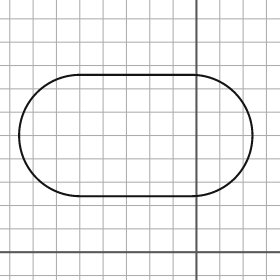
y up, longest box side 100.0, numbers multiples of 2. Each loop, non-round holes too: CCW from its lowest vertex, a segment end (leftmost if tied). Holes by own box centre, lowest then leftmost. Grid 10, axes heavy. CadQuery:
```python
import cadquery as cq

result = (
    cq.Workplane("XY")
    .moveTo(-50.0, 24.0)
    .lineTo(-2.0, 24.0)
    .threePointArc((24.0, 50.0), (-2.0, 76.0))
    .lineTo(-50.0, 76.0)
    .threePointArc((-76.0, 50.0), (-50.0, 24.0))
    .close()
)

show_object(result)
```